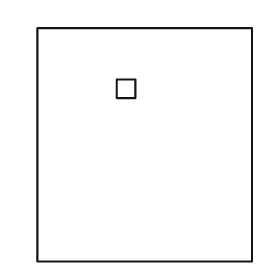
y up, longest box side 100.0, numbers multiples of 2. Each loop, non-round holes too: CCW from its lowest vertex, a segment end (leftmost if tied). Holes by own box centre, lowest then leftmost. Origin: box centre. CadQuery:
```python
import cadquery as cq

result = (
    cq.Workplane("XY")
    .moveTo(-46.0, -50.0)
    .lineTo(46.0, -50.0)
    .lineTo(46.0, 50.0)
    .lineTo(-46.0, 50.0)
    .close()
    .moveTo(-12.0, 20.0)
    .lineTo(-4.0, 20.0)
    .lineTo(-4.0, 28.0)
    .lineTo(-12.0, 28.0)
    .close()
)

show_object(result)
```